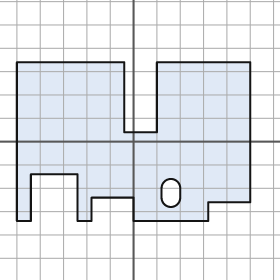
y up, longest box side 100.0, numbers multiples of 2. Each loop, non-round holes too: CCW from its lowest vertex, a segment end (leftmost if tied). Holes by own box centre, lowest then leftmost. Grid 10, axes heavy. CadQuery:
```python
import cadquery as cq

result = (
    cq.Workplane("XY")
    .moveTo(-50.0, -34.0)
    .lineTo(-44.0, -34.0)
    .lineTo(-44.0, -14.0)
    .lineTo(-24.0, -14.0)
    .lineTo(-24.0, -34.0)
    .lineTo(-18.0, -34.0)
    .lineTo(-18.0, -24.0)
    .lineTo(0.0, -24.0)
    .lineTo(0.0, -34.0)
    .lineTo(32.0, -34.0)
    .lineTo(32.0, -26.0)
    .lineTo(50.0, -26.0)
    .lineTo(50.0, 34.0)
    .lineTo(10.0, 34.0)
    .lineTo(10.0, 4.0)
    .lineTo(-4.0, 4.0)
    .lineTo(-4.0, 34.0)
    .lineTo(-50.0, 34.0)
    .close()
    .moveTo(12.0, -24.0)
    .threePointArc((16.0, -28.0), (20.0, -24.0))
    .lineTo(20.0, -20.0)
    .threePointArc((16.0, -16.0), (12.0, -20.0))
    .close()
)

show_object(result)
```